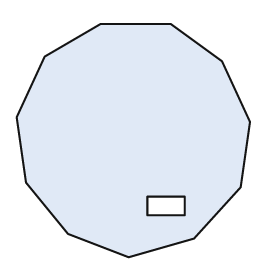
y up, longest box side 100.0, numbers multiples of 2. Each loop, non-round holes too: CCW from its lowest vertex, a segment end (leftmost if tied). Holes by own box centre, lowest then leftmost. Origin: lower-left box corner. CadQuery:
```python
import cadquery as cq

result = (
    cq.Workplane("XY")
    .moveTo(48.0, 0.0)
    .lineTo(76.0, 8.0)
    .lineTo(96.0, 30.0)
    .lineTo(100.0, 58.0)
    .lineTo(88.0, 84.0)
    .lineTo(66.0, 100.0)
    .lineTo(36.0, 100.0)
    .lineTo(12.0, 86.0)
    .lineTo(0.0, 60.0)
    .lineTo(4.0, 32.0)
    .lineTo(22.0, 10.0)
    .close()
    .moveTo(56.0, 18.0)
    .lineTo(72.0, 18.0)
    .lineTo(72.0, 26.0)
    .lineTo(56.0, 26.0)
    .close()
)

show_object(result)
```